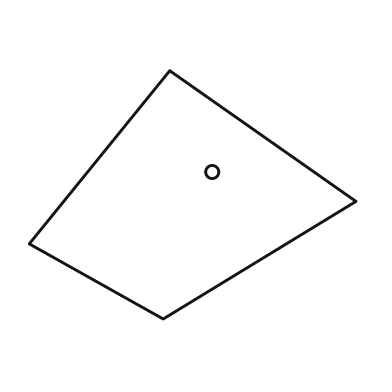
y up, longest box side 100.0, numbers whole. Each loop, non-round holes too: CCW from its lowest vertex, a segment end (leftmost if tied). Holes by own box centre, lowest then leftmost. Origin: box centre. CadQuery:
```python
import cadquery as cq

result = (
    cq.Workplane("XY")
    .moveTo(-9.0, -38.0)
    .lineTo(50.0, -2.0)
    .lineTo(-7.0, 38.0)
    .lineTo(-50.0, -15.0)
    .close()
    .moveTo(6.0, 7.0)
    .circle(2.0)
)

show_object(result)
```